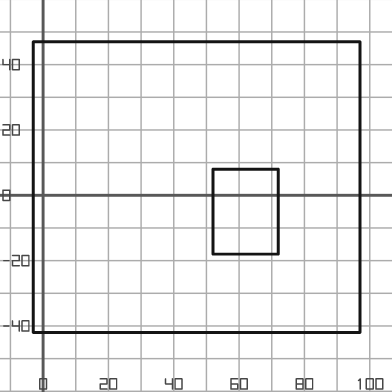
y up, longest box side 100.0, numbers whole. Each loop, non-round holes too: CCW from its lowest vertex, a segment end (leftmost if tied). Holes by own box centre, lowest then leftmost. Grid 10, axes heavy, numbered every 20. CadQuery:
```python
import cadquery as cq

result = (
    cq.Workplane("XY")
    .moveTo(-3.0, -42.0)
    .lineTo(97.0, -42.0)
    .lineTo(97.0, 47.0)
    .lineTo(-3.0, 47.0)
    .close()
    .moveTo(52.0, -18.0)
    .lineTo(72.0, -18.0)
    .lineTo(72.0, 8.0)
    .lineTo(52.0, 8.0)
    .close()
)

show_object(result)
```